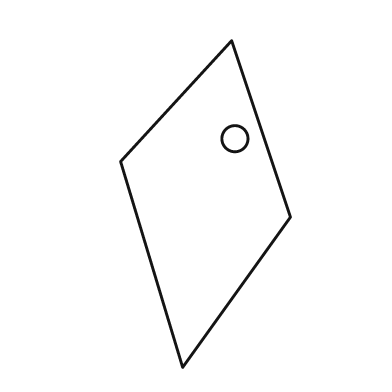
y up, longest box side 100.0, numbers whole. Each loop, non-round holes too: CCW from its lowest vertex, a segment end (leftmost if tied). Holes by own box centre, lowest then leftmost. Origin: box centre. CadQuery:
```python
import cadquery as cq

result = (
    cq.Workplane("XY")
    .moveTo(-7.0, -50.0)
    .lineTo(26.0, -4.0)
    .lineTo(8.0, 50.0)
    .lineTo(-26.0, 13.0)
    .close()
    .moveTo(9.0, 20.0)
    .circle(4.0)
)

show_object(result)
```